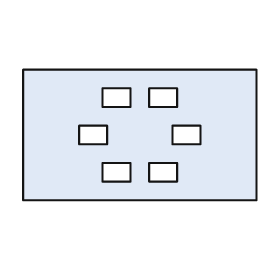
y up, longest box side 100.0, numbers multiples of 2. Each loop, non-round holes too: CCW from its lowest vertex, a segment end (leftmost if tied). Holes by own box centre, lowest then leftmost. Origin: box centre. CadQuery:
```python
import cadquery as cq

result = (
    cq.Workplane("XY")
    .moveTo(-50.0, -28.0)
    .lineTo(50.0, -28.0)
    .lineTo(50.0, 28.0)
    .lineTo(-50.0, 28.0)
    .close()
    .moveTo(-16.0, -20.0)
    .lineTo(-4.0, -20.0)
    .lineTo(-4.0, -12.0)
    .lineTo(-16.0, -12.0)
    .close()
    .moveTo(4.0, -20.0)
    .lineTo(16.0, -20.0)
    .lineTo(16.0, -12.0)
    .lineTo(4.0, -12.0)
    .close()
    .moveTo(-26.0, -4.0)
    .lineTo(-14.0, -4.0)
    .lineTo(-14.0, 4.0)
    .lineTo(-26.0, 4.0)
    .close()
    .moveTo(14.0, -4.0)
    .lineTo(26.0, -4.0)
    .lineTo(26.0, 4.0)
    .lineTo(14.0, 4.0)
    .close()
    .moveTo(-16.0, 12.0)
    .lineTo(-4.0, 12.0)
    .lineTo(-4.0, 20.0)
    .lineTo(-16.0, 20.0)
    .close()
    .moveTo(4.0, 12.0)
    .lineTo(16.0, 12.0)
    .lineTo(16.0, 20.0)
    .lineTo(4.0, 20.0)
    .close()
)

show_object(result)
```